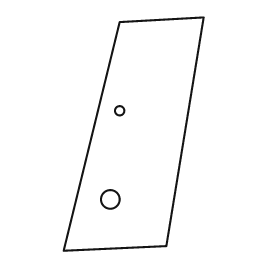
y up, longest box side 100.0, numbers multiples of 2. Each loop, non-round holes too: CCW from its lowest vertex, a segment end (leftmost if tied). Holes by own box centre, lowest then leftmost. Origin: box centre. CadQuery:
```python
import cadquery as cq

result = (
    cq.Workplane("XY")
    .moveTo(-30.0, -50.0)
    .lineTo(14.0, -48.0)
    .lineTo(30.0, 50.0)
    .lineTo(-6.0, 48.0)
    .close()
    .moveTo(-10.0, -28.0)
    .circle(4.0)
    .moveTo(-6.0, 10.0)
    .circle(2.0)
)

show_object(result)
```